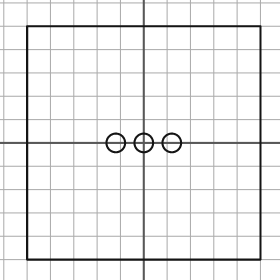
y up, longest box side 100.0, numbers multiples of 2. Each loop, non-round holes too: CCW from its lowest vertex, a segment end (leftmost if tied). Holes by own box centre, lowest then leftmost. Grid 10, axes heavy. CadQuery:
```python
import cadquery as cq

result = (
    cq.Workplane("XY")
    .moveTo(-50.0, -50.0)
    .lineTo(50.0, -50.0)
    .lineTo(50.0, 50.0)
    .lineTo(-50.0, 50.0)
    .close()
    .moveTo(-12.0, 0.0)
    .circle(4.0)
    .moveTo(0.0, 0.0)
    .circle(4.0)
    .moveTo(12.0, 0.0)
    .circle(4.0)
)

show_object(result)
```